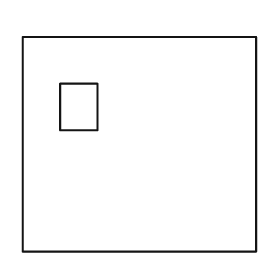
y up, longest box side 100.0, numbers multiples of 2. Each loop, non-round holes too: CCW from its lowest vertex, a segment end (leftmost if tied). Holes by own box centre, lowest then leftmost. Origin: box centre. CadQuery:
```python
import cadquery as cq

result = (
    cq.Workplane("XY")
    .moveTo(-50.0, -46.0)
    .lineTo(50.0, -46.0)
    .lineTo(50.0, 46.0)
    .lineTo(-50.0, 46.0)
    .close()
    .moveTo(-34.0, 6.0)
    .lineTo(-18.0, 6.0)
    .lineTo(-18.0, 26.0)
    .lineTo(-34.0, 26.0)
    .close()
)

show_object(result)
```